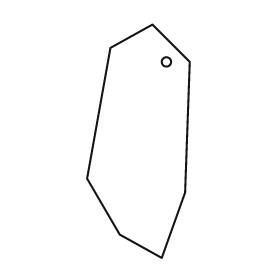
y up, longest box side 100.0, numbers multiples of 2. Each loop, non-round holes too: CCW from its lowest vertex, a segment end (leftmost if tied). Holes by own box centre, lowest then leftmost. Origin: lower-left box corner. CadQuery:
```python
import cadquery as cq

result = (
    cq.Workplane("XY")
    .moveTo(32.0, 0.0)
    .lineTo(42.0, 28.0)
    .lineTo(44.0, 84.0)
    .lineTo(28.0, 100.0)
    .lineTo(10.0, 90.0)
    .lineTo(0.0, 34.0)
    .lineTo(14.0, 10.0)
    .close()
    .moveTo(34.0, 84.0)
    .circle(2.0)
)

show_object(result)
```